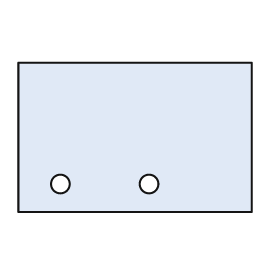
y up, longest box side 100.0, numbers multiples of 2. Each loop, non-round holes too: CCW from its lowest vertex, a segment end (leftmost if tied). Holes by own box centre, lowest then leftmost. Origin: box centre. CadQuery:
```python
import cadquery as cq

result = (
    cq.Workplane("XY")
    .moveTo(-50.0, -32.0)
    .lineTo(50.0, -32.0)
    .lineTo(50.0, 32.0)
    .lineTo(-50.0, 32.0)
    .close()
    .moveTo(-32.0, -20.0)
    .circle(4.0)
    .moveTo(6.0, -20.0)
    .circle(4.0)
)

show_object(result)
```